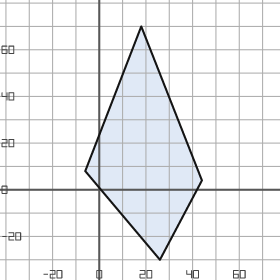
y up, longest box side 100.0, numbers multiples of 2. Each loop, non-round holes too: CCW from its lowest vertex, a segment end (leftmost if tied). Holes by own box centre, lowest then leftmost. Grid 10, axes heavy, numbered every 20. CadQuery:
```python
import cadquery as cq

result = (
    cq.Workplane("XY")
    .moveTo(26.0, -30.0)
    .lineTo(44.0, 4.0)
    .lineTo(18.0, 70.0)
    .lineTo(-6.0, 8.0)
    .close()
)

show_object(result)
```